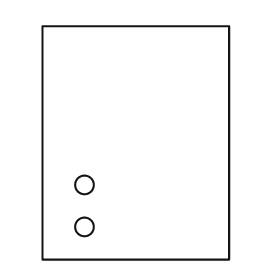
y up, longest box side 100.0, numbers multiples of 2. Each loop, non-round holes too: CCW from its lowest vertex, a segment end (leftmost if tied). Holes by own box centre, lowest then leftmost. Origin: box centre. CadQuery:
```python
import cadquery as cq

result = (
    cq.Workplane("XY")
    .moveTo(-40.0, -50.0)
    .lineTo(40.0, -50.0)
    .lineTo(40.0, 50.0)
    .lineTo(-40.0, 50.0)
    .close()
    .moveTo(-22.0, -36.0)
    .circle(4.0)
    .moveTo(-22.0, -18.0)
    .circle(4.0)
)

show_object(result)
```